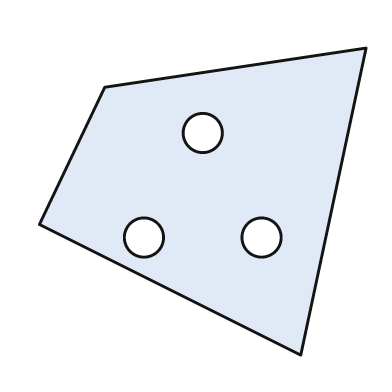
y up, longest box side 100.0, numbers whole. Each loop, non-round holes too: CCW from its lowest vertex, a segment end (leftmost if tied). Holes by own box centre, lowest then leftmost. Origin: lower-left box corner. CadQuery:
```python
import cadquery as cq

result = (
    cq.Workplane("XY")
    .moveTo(80.0, 0.0)
    .lineTo(100.0, 94.0)
    .lineTo(20.0, 82.0)
    .lineTo(0.0, 40.0)
    .close()
    .moveTo(32.0, 36.0)
    .circle(6.0)
    .moveTo(68.0, 36.0)
    .circle(6.0)
    .moveTo(50.0, 68.0)
    .circle(6.0)
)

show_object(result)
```